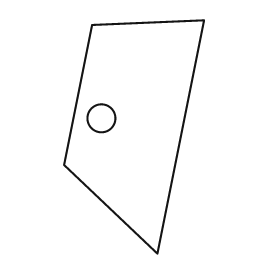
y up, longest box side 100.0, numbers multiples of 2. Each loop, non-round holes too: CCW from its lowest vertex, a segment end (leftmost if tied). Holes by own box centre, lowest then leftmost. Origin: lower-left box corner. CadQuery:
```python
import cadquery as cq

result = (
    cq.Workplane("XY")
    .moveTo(40.0, 0.0)
    .lineTo(60.0, 100.0)
    .lineTo(12.0, 98.0)
    .lineTo(0.0, 38.0)
    .close()
    .moveTo(16.0, 58.0)
    .circle(6.0)
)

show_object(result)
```